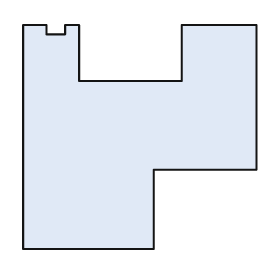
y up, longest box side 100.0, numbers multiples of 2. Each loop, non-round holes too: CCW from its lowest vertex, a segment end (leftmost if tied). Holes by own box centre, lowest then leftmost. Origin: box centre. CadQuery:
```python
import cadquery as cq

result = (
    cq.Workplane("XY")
    .moveTo(-50.0, -48.0)
    .lineTo(6.0, -48.0)
    .lineTo(6.0, -14.0)
    .lineTo(50.0, -14.0)
    .lineTo(50.0, 48.0)
    .lineTo(18.0, 48.0)
    .lineTo(18.0, 24.0)
    .lineTo(-26.0, 24.0)
    .lineTo(-26.0, 48.0)
    .lineTo(-32.0, 48.0)
    .lineTo(-32.0, 44.0)
    .lineTo(-40.0, 44.0)
    .lineTo(-40.0, 48.0)
    .lineTo(-50.0, 48.0)
    .close()
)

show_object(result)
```